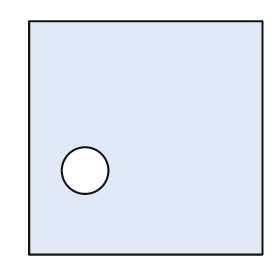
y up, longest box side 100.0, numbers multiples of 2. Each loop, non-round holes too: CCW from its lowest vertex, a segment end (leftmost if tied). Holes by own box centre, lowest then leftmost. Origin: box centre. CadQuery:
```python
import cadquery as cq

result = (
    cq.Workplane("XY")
    .moveTo(-50.0, -50.0)
    .lineTo(50.0, -50.0)
    .lineTo(50.0, 50.0)
    .lineTo(-50.0, 50.0)
    .close()
    .moveTo(-26.0, -14.0)
    .circle(10.0)
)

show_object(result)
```